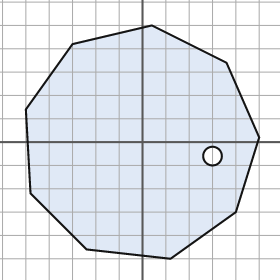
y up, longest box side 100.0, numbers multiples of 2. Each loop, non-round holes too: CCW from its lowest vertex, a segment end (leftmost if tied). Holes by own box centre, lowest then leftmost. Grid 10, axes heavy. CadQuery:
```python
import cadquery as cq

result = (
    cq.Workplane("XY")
    .moveTo(12.0, -50.0)
    .lineTo(40.0, -30.0)
    .lineTo(50.0, 2.0)
    .lineTo(36.0, 34.0)
    .lineTo(4.0, 50.0)
    .lineTo(-30.0, 42.0)
    .lineTo(-50.0, 14.0)
    .lineTo(-48.0, -22.0)
    .lineTo(-24.0, -46.0)
    .close()
    .moveTo(30.0, -6.0)
    .circle(4.0)
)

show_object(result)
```